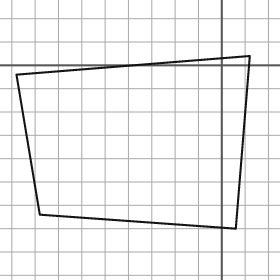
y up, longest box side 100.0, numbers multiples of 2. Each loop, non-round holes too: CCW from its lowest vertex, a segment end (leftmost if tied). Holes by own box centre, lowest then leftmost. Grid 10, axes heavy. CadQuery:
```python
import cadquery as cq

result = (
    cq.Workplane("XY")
    .moveTo(6.0, -70.0)
    .lineTo(12.0, 4.0)
    .lineTo(-88.0, -4.0)
    .lineTo(-78.0, -64.0)
    .close()
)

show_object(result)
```